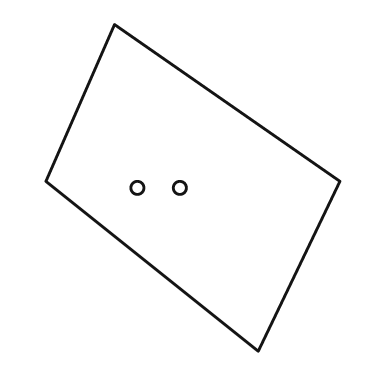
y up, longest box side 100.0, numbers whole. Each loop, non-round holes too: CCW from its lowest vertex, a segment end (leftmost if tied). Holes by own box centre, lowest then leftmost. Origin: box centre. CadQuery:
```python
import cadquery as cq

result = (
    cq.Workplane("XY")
    .moveTo(20.0, -50.0)
    .lineTo(45.0, 2.0)
    .lineTo(-24.0, 50.0)
    .lineTo(-45.0, 2.0)
    .close()
    .moveTo(-17.0, 0.0)
    .circle(2.0)
    .moveTo(-4.0, 0.0)
    .circle(2.0)
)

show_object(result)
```